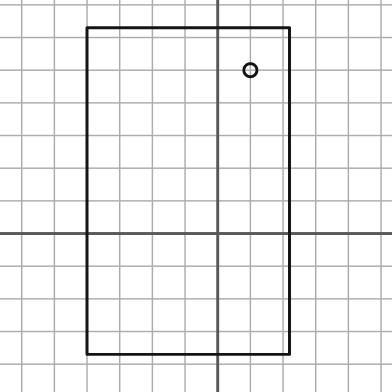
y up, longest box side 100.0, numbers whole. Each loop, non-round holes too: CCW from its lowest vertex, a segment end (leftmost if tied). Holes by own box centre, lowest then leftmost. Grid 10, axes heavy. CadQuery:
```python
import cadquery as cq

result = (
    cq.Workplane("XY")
    .moveTo(-40.0, -37.0)
    .lineTo(22.0, -37.0)
    .lineTo(22.0, 63.0)
    .lineTo(-40.0, 63.0)
    .close()
    .moveTo(10.0, 50.0)
    .circle(2.0)
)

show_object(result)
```